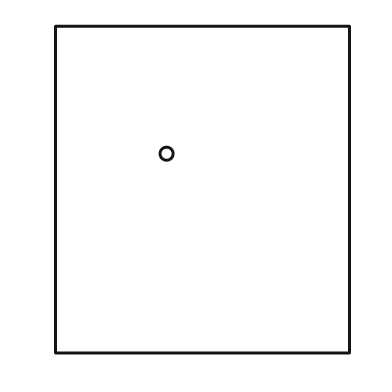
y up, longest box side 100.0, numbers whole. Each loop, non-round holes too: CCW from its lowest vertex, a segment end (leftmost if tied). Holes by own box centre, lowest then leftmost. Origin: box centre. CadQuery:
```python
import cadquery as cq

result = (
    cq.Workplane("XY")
    .moveTo(-45.0, -50.0)
    .lineTo(45.0, -50.0)
    .lineTo(45.0, 50.0)
    .lineTo(-45.0, 50.0)
    .close()
    .moveTo(-11.0, 11.0)
    .circle(2.0)
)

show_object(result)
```